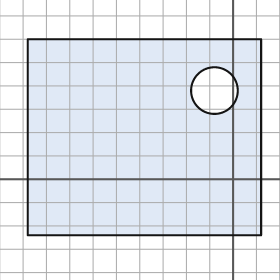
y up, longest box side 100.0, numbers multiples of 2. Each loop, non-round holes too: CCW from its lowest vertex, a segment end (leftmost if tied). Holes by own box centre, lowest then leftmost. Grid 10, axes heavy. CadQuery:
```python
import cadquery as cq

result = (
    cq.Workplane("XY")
    .moveTo(-88.0, -24.0)
    .lineTo(12.0, -24.0)
    .lineTo(12.0, 60.0)
    .lineTo(-88.0, 60.0)
    .close()
    .moveTo(-8.0, 38.0)
    .circle(10.0)
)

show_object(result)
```